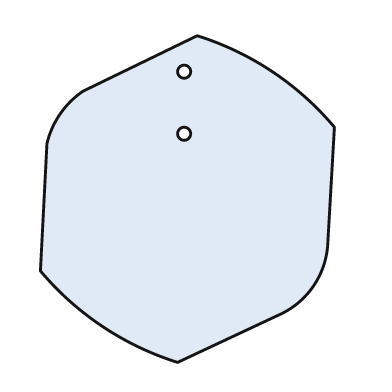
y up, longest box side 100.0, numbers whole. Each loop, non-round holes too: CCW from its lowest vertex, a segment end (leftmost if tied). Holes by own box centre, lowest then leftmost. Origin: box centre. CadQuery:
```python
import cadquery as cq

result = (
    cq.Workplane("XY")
    .moveTo(-3.0, -50.0)
    .lineTo(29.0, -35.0)
    .threePointArc((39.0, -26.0), (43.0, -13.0))
    .lineTo(45.0, 22.0)
    .threePointArc((26.0, 39.0), (3.0, 50.0))
    .lineTo(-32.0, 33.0)
    .threePointArc((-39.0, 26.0), (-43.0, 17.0))
    .lineTo(-45.0, -22.0)
    .threePointArc((-26.0, -39.0), (-3.0, -50.0))
    .close()
    .moveTo(-1.0, 20.0)
    .circle(2.0)
    .moveTo(-1.0, 39.0)
    .circle(2.0)
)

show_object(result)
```